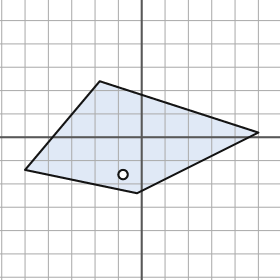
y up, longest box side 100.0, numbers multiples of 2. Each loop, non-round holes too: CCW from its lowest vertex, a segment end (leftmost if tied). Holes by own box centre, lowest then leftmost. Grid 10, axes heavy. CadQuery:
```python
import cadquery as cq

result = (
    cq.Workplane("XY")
    .moveTo(-2.0, -24.0)
    .lineTo(50.0, 2.0)
    .lineTo(-18.0, 24.0)
    .lineTo(-50.0, -14.0)
    .close()
    .moveTo(-8.0, -16.0)
    .circle(2.0)
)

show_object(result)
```